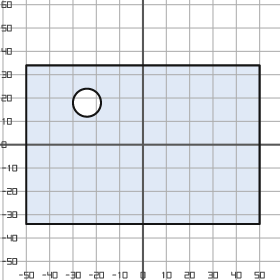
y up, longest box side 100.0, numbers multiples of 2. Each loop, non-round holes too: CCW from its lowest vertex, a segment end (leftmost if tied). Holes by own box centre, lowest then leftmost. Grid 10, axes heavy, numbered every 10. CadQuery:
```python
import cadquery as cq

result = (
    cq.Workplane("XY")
    .moveTo(-50.0, -34.0)
    .lineTo(50.0, -34.0)
    .lineTo(50.0, 34.0)
    .lineTo(-50.0, 34.0)
    .close()
    .moveTo(-24.0, 18.0)
    .circle(6.0)
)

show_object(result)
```